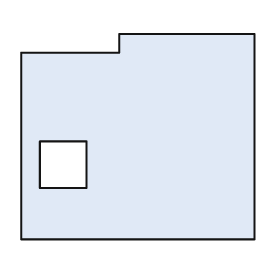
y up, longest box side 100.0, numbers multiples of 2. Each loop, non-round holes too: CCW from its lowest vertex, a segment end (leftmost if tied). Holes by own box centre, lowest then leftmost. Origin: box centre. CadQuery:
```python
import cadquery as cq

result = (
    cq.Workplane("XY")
    .moveTo(-50.0, -44.0)
    .lineTo(50.0, -44.0)
    .lineTo(50.0, 44.0)
    .lineTo(-8.0, 44.0)
    .lineTo(-8.0, 36.0)
    .lineTo(-50.0, 36.0)
    .close()
    .moveTo(-42.0, -22.0)
    .lineTo(-22.0, -22.0)
    .lineTo(-22.0, -2.0)
    .lineTo(-42.0, -2.0)
    .close()
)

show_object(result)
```